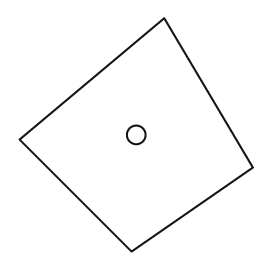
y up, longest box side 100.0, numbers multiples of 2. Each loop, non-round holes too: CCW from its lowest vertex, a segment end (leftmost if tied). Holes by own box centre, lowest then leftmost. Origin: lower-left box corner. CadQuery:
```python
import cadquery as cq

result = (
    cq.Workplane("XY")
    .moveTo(48.0, 0.0)
    .lineTo(100.0, 36.0)
    .lineTo(62.0, 100.0)
    .lineTo(0.0, 48.0)
    .close()
    .moveTo(50.0, 50.0)
    .circle(4.0)
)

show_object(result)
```